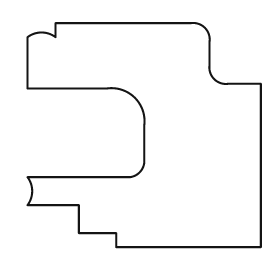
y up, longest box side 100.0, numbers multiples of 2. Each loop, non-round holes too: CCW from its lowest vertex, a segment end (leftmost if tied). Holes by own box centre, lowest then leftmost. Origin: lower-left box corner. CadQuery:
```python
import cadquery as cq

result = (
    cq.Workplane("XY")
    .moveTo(38.0, 0.0)
    .lineTo(100.0, 0.0)
    .lineTo(100.0, 70.0)
    .lineTo(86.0, 70.0)
    .threePointArc((80.0, 72.0), (78.0, 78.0))
    .lineTo(78.0, 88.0)
    .threePointArc((76.0, 94.0), (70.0, 96.0))
    .lineTo(12.0, 96.0)
    .lineTo(12.0, 90.0)
    .threePointArc((6.0, 92.0), (0.0, 90.0))
    .lineTo(0.0, 68.0)
    .lineTo(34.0, 68.0)
    .threePointArc((46.0, 64.0), (50.0, 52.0))
    .lineTo(50.0, 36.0)
    .threePointArc((48.0, 32.0), (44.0, 30.0))
    .lineTo(0.0, 30.0)
    .threePointArc((2.0, 24.0), (0.0, 18.0))
    .lineTo(22.0, 18.0)
    .lineTo(22.0, 6.0)
    .lineTo(38.0, 6.0)
    .close()
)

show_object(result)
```